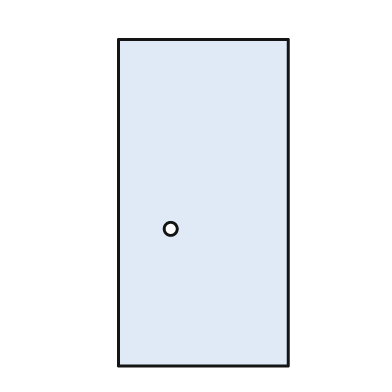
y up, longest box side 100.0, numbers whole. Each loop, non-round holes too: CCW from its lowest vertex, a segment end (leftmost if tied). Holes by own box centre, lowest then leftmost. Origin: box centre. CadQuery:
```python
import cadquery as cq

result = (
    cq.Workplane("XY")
    .moveTo(-26.0, -50.0)
    .lineTo(26.0, -50.0)
    .lineTo(26.0, 50.0)
    .lineTo(-26.0, 50.0)
    .close()
    .moveTo(-10.0, -8.0)
    .circle(2.0)
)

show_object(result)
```